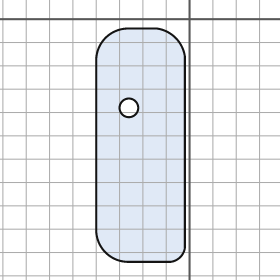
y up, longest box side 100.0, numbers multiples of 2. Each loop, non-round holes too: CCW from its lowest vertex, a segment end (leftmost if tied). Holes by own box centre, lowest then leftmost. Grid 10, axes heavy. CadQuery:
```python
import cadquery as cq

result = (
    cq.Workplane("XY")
    .moveTo(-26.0, -104.0)
    .lineTo(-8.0, -104.0)
    .threePointArc((-4.0, -102.0), (-2.0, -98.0))
    .lineTo(-2.0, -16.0)
    .threePointArc((-6.0, -8.0), (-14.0, -4.0))
    .lineTo(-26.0, -4.0)
    .threePointArc((-36.0, -8.0), (-40.0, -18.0))
    .lineTo(-40.0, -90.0)
    .threePointArc((-36.0, -100.0), (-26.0, -104.0))
    .close()
    .moveTo(-26.0, -38.0)
    .circle(4.0)
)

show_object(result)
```